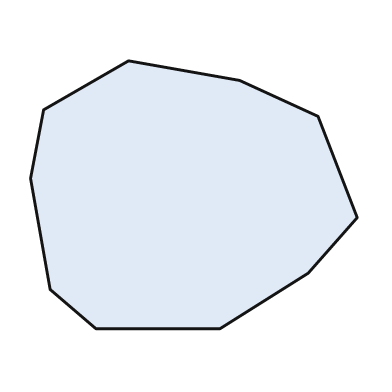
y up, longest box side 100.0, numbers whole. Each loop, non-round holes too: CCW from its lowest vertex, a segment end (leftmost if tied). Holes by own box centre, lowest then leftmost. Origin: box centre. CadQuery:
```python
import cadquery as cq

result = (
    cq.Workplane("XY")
    .moveTo(-30.0, -41.0)
    .lineTo(8.0, -41.0)
    .lineTo(35.0, -24.0)
    .lineTo(50.0, -7.0)
    .lineTo(38.0, 24.0)
    .lineTo(14.0, 35.0)
    .lineTo(-20.0, 41.0)
    .lineTo(-46.0, 26.0)
    .lineTo(-50.0, 5.0)
    .lineTo(-44.0, -29.0)
    .close()
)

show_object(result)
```